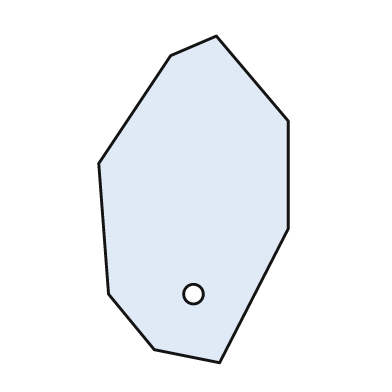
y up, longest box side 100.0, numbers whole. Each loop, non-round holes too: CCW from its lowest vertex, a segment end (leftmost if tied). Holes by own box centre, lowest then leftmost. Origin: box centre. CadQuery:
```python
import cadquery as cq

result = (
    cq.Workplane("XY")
    .moveTo(8.0, -50.0)
    .lineTo(29.0, -9.0)
    .lineTo(29.0, 24.0)
    .lineTo(7.0, 50.0)
    .lineTo(-7.0, 44.0)
    .lineTo(-29.0, 11.0)
    .lineTo(-26.0, -29.0)
    .lineTo(-12.0, -46.0)
    .close()
    .moveTo(0.0, -29.0)
    .circle(3.0)
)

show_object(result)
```